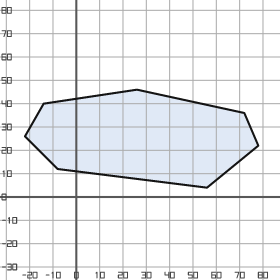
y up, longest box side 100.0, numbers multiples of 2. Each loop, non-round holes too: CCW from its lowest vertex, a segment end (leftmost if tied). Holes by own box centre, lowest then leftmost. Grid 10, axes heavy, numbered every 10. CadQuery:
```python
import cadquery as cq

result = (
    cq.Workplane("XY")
    .moveTo(56.0, 4.0)
    .lineTo(78.0, 22.0)
    .lineTo(72.0, 36.0)
    .lineTo(26.0, 46.0)
    .lineTo(-14.0, 40.0)
    .lineTo(-22.0, 26.0)
    .lineTo(-8.0, 12.0)
    .close()
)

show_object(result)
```